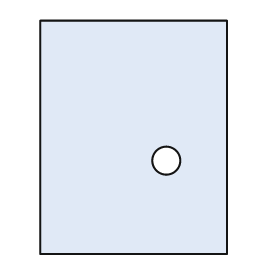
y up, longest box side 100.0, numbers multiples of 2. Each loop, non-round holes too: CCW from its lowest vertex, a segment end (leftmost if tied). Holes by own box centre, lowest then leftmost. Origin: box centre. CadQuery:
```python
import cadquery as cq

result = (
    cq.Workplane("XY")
    .moveTo(-40.0, -50.0)
    .lineTo(40.0, -50.0)
    .lineTo(40.0, 50.0)
    .lineTo(-40.0, 50.0)
    .close()
    .moveTo(14.0, -10.0)
    .circle(6.0)
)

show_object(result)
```